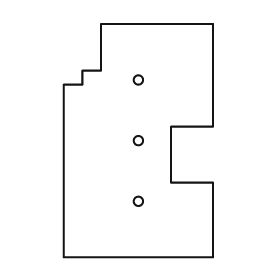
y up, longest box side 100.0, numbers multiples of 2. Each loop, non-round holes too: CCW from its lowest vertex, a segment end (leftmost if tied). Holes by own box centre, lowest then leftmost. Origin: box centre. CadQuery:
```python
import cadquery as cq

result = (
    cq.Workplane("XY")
    .moveTo(-32.0, -50.0)
    .lineTo(32.0, -50.0)
    .lineTo(32.0, -18.0)
    .lineTo(14.0, -18.0)
    .lineTo(14.0, 6.0)
    .lineTo(32.0, 6.0)
    .lineTo(32.0, 50.0)
    .lineTo(-16.0, 50.0)
    .lineTo(-16.0, 30.0)
    .lineTo(-24.0, 30.0)
    .lineTo(-24.0, 24.0)
    .lineTo(-32.0, 24.0)
    .close()
    .moveTo(0.0, -26.0)
    .circle(2.0)
    .moveTo(0.0, 0.0)
    .circle(2.0)
    .moveTo(0.0, 26.0)
    .circle(2.0)
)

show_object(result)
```